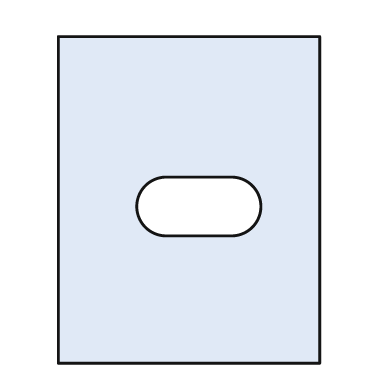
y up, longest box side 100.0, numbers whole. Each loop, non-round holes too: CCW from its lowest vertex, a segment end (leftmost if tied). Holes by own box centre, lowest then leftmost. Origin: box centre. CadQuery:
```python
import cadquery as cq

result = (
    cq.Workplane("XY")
    .moveTo(-40.0, -50.0)
    .lineTo(40.0, -50.0)
    .lineTo(40.0, 50.0)
    .lineTo(-40.0, 50.0)
    .close()
    .moveTo(-7.0, -11.0)
    .lineTo(13.0, -11.0)
    .threePointArc((22.0, -2.0), (13.0, 7.0))
    .lineTo(-7.0, 7.0)
    .threePointArc((-16.0, -2.0), (-7.0, -11.0))
    .close()
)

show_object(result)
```